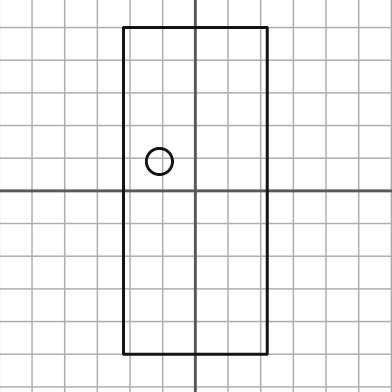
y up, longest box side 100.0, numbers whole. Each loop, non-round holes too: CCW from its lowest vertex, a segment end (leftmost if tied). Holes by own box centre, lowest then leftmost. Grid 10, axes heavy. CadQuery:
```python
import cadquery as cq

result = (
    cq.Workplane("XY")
    .moveTo(-22.0, -50.0)
    .lineTo(22.0, -50.0)
    .lineTo(22.0, 50.0)
    .lineTo(-22.0, 50.0)
    .close()
    .moveTo(-11.0, 9.0)
    .circle(4.0)
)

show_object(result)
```